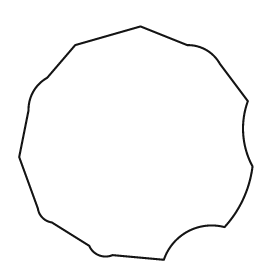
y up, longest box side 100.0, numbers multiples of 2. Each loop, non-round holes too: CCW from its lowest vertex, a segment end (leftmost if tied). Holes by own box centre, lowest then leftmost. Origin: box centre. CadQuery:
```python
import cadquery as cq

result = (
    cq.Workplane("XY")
    .moveTo(12.0, -50.0)
    .threePointArc((22.0, -38.0), (38.0, -36.0))
    .threePointArc((46.0, -24.0), (50.0, -10.0))
    .threePointArc((46.0, 4.0), (48.0, 18.0))
    .lineTo(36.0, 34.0)
    .threePointArc((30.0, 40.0), (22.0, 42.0))
    .lineTo(2.0, 50.0)
    .lineTo(-26.0, 42.0)
    .lineTo(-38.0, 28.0)
    .threePointArc((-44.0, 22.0), (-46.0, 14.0))
    .lineTo(-50.0, -6.0)
    .lineTo(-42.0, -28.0)
    .threePointArc((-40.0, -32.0), (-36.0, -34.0))
    .lineTo(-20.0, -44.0)
    .threePointArc((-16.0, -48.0), (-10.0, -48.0))
    .close()
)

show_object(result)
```